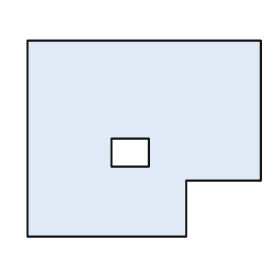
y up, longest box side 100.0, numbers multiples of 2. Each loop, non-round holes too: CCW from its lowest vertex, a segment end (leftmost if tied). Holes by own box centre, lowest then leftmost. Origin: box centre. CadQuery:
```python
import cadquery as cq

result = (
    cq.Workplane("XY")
    .moveTo(-50.0, -42.0)
    .lineTo(18.0, -42.0)
    .lineTo(18.0, -18.0)
    .lineTo(50.0, -18.0)
    .lineTo(50.0, 42.0)
    .lineTo(-50.0, 42.0)
    .close()
    .moveTo(-14.0, -12.0)
    .lineTo(2.0, -12.0)
    .lineTo(2.0, 0.0)
    .lineTo(-14.0, 0.0)
    .close()
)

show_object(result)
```